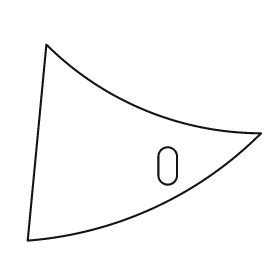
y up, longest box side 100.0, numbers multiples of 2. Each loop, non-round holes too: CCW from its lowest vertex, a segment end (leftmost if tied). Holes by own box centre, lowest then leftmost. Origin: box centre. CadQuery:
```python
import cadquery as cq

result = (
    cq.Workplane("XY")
    .moveTo(-50.0, -42.0)
    .threePointArc((4.0, -28.0), (50.0, 4.0))
    .threePointArc((0.0, 14.0), (-42.0, 42.0))
    .close()
    .moveTo(6.0, -14.0)
    .threePointArc((10.0, -18.0), (14.0, -14.0))
    .lineTo(14.0, -6.0)
    .threePointArc((10.0, -2.0), (6.0, -6.0))
    .close()
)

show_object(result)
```